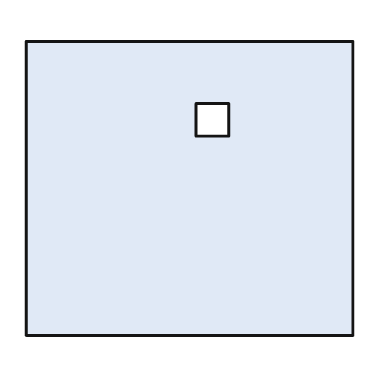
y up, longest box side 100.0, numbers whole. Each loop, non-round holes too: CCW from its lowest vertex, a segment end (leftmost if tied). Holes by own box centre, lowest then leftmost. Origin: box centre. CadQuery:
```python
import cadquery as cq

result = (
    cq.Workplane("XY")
    .moveTo(-50.0, -45.0)
    .lineTo(50.0, -45.0)
    .lineTo(50.0, 45.0)
    .lineTo(-50.0, 45.0)
    .close()
    .moveTo(2.0, 16.0)
    .lineTo(12.0, 16.0)
    .lineTo(12.0, 26.0)
    .lineTo(2.0, 26.0)
    .close()
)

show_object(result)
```